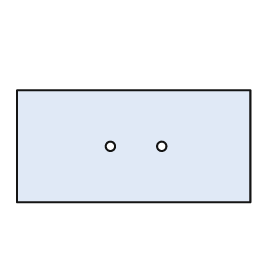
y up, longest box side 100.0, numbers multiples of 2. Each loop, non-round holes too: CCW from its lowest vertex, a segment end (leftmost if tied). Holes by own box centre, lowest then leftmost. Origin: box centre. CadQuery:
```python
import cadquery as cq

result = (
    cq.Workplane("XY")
    .moveTo(-50.0, -24.0)
    .lineTo(50.0, -24.0)
    .lineTo(50.0, 24.0)
    .lineTo(-50.0, 24.0)
    .close()
    .moveTo(-10.0, 0.0)
    .circle(2.0)
    .moveTo(12.0, 0.0)
    .circle(2.0)
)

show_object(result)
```